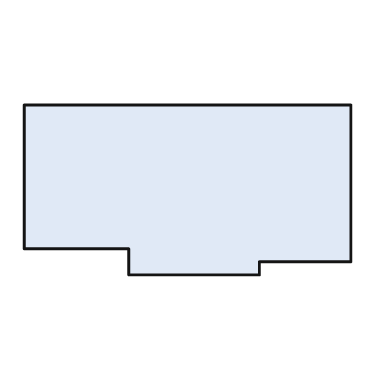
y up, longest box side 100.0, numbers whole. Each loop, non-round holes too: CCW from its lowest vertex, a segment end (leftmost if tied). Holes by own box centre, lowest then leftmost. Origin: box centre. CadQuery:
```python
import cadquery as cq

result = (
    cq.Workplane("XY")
    .moveTo(-18.0, -26.0)
    .lineTo(22.0, -26.0)
    .lineTo(22.0, -22.0)
    .lineTo(50.0, -22.0)
    .lineTo(50.0, 26.0)
    .lineTo(-50.0, 26.0)
    .lineTo(-50.0, -18.0)
    .lineTo(-18.0, -18.0)
    .close()
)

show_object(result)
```